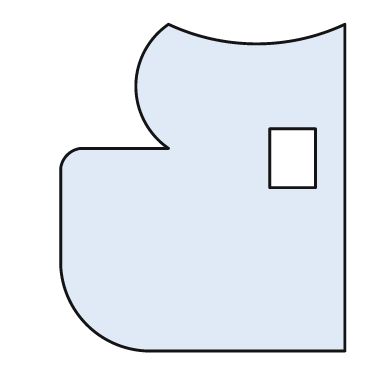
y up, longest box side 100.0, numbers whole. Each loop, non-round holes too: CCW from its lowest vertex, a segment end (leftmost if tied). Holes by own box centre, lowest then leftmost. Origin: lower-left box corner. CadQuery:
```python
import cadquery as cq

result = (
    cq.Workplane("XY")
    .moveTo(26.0, 0.0)
    .lineTo(87.0, 0.0)
    .lineTo(87.0, 100.0)
    .threePointArc((60.0, 94.0), (33.0, 100.0))
    .threePointArc((23.0, 81.0), (33.0, 62.0))
    .lineTo(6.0, 62.0)
    .threePointArc((2.0, 60.0), (0.0, 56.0))
    .lineTo(0.0, 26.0)
    .threePointArc((8.0, 8.0), (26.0, 0.0))
    .close()
    .moveTo(64.0, 50.0)
    .lineTo(78.0, 50.0)
    .lineTo(78.0, 68.0)
    .lineTo(64.0, 68.0)
    .close()
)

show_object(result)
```